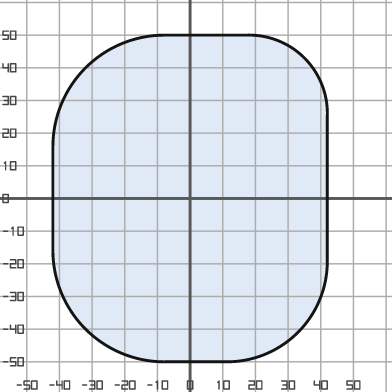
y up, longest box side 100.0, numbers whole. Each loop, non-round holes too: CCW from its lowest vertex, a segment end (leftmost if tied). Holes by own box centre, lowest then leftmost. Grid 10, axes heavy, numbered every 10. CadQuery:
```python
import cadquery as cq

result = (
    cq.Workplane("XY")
    .moveTo(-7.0, -50.0)
    .lineTo(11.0, -50.0)
    .threePointArc((33.0, -41.0), (42.0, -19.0))
    .lineTo(42.0, 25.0)
    .threePointArc((35.0, 43.0), (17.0, 50.0))
    .lineTo(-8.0, 50.0)
    .threePointArc((-32.0, 40.0), (-42.0, 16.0))
    .lineTo(-42.0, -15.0)
    .threePointArc((-32.0, -40.0), (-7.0, -50.0))
    .close()
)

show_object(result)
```